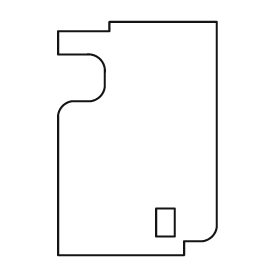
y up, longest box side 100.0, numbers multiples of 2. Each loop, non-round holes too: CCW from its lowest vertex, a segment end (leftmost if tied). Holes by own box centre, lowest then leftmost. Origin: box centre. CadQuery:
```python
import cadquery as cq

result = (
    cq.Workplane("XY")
    .moveTo(-34.0, -50.0)
    .lineTo(20.0, -50.0)
    .lineTo(20.0, -44.0)
    .lineTo(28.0, -44.0)
    .threePointArc((32.0, -42.0), (34.0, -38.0))
    .lineTo(34.0, 50.0)
    .lineTo(-12.0, 50.0)
    .lineTo(-12.0, 46.0)
    .lineTo(-34.0, 46.0)
    .lineTo(-34.0, 36.0)
    .lineTo(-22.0, 36.0)
    .threePointArc((-16.0, 34.0), (-14.0, 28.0))
    .lineTo(-14.0, 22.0)
    .threePointArc((-16.0, 18.0), (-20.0, 16.0))
    .lineTo(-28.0, 16.0)
    .threePointArc((-32.0, 14.0), (-34.0, 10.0))
    .close()
    .moveTo(8.0, -42.0)
    .lineTo(16.0, -42.0)
    .lineTo(16.0, -30.0)
    .lineTo(8.0, -30.0)
    .close()
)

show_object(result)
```